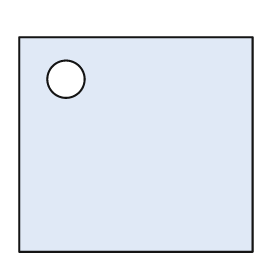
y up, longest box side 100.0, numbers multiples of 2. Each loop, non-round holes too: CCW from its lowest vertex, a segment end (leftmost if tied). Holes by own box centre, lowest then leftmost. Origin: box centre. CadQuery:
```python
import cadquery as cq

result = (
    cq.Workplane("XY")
    .moveTo(-50.0, -46.0)
    .lineTo(50.0, -46.0)
    .lineTo(50.0, 46.0)
    .lineTo(-50.0, 46.0)
    .close()
    .moveTo(-30.0, 28.0)
    .circle(8.0)
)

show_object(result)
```